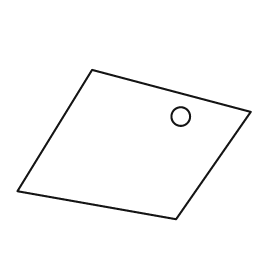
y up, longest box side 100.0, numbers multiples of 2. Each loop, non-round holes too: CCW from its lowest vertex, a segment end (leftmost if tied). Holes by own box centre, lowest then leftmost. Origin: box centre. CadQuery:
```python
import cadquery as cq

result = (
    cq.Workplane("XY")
    .moveTo(18.0, -32.0)
    .lineTo(50.0, 14.0)
    .lineTo(-18.0, 32.0)
    .lineTo(-50.0, -20.0)
    .close()
    .moveTo(20.0, 12.0)
    .circle(4.0)
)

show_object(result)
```